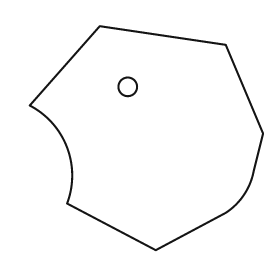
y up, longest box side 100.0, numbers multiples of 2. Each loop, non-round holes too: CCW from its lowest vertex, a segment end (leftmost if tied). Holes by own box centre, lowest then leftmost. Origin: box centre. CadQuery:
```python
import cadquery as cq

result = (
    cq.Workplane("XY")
    .moveTo(4.0, -48.0)
    .lineTo(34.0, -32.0)
    .threePointArc((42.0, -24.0), (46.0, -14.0))
    .lineTo(50.0, 2.0)
    .lineTo(34.0, 40.0)
    .lineTo(-20.0, 48.0)
    .lineTo(-50.0, 14.0)
    .threePointArc((-34.0, -4.0), (-34.0, -28.0))
    .close()
    .moveTo(-8.0, 22.0)
    .circle(4.0)
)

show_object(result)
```